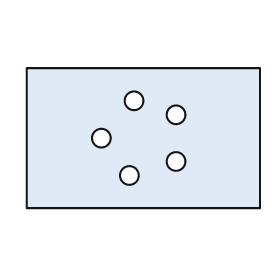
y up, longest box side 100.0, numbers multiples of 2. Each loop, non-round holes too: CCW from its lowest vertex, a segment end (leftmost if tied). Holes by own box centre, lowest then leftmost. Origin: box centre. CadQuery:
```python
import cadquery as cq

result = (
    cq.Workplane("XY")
    .moveTo(-50.0, -30.0)
    .lineTo(50.0, -30.0)
    .lineTo(50.0, 30.0)
    .lineTo(-50.0, 30.0)
    .close()
    .moveTo(-6.0, -16.0)
    .circle(4.0)
    .moveTo(14.0, -10.0)
    .circle(4.0)
    .moveTo(-18.0, 0.0)
    .circle(4.0)
    .moveTo(14.0, 10.0)
    .circle(4.0)
    .moveTo(-4.0, 16.0)
    .circle(4.0)
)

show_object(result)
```